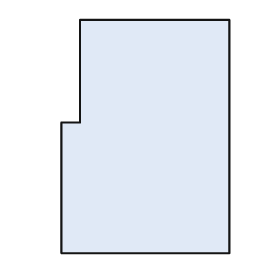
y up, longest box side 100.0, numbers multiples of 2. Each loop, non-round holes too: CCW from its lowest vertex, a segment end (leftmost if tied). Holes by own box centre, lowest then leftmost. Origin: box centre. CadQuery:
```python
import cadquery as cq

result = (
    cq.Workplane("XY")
    .moveTo(-36.0, -50.0)
    .lineTo(36.0, -50.0)
    .lineTo(36.0, 50.0)
    .lineTo(-28.0, 50.0)
    .lineTo(-28.0, 6.0)
    .lineTo(-36.0, 6.0)
    .close()
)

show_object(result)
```